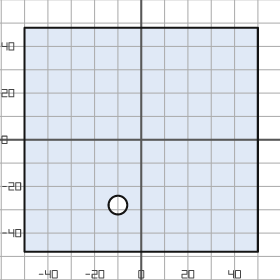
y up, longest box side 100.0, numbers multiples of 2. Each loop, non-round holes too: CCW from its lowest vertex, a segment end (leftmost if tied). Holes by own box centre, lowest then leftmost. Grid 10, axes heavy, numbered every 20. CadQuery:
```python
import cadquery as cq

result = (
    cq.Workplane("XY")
    .moveTo(-50.0, -48.0)
    .lineTo(50.0, -48.0)
    .lineTo(50.0, 48.0)
    .lineTo(-50.0, 48.0)
    .close()
    .moveTo(-10.0, -28.0)
    .circle(4.0)
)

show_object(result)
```